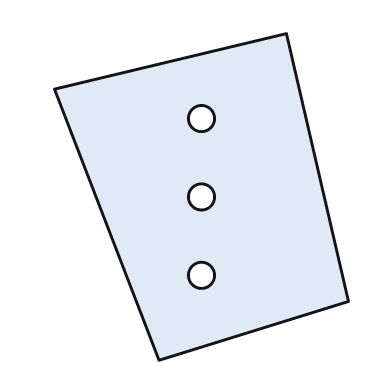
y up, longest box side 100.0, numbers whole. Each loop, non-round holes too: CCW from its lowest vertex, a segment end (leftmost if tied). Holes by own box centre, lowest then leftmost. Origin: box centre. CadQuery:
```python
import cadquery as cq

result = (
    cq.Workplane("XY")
    .moveTo(-13.0, -50.0)
    .lineTo(45.0, -32.0)
    .lineTo(26.0, 50.0)
    .lineTo(-45.0, 33.0)
    .close()
    .moveTo(0.0, -24.0)
    .circle(4.0)
    .moveTo(0.0, 0.0)
    .circle(4.0)
    .moveTo(0.0, 24.0)
    .circle(4.0)
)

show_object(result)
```